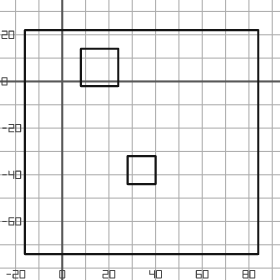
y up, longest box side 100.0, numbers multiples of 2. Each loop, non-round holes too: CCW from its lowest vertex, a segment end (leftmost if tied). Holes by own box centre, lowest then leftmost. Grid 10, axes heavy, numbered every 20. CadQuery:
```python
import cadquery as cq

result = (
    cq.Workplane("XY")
    .moveTo(-16.0, -74.0)
    .lineTo(84.0, -74.0)
    .lineTo(84.0, 22.0)
    .lineTo(-16.0, 22.0)
    .close()
    .moveTo(28.0, -44.0)
    .lineTo(40.0, -44.0)
    .lineTo(40.0, -32.0)
    .lineTo(28.0, -32.0)
    .close()
    .moveTo(8.0, -2.0)
    .lineTo(24.0, -2.0)
    .lineTo(24.0, 14.0)
    .lineTo(8.0, 14.0)
    .close()
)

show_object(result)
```